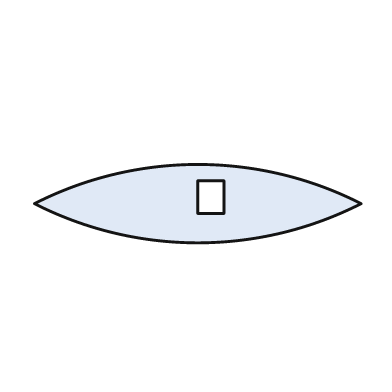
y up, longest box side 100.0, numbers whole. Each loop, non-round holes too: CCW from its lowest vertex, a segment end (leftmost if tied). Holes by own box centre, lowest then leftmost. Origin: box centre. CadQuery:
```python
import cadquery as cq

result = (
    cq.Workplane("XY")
    .moveTo(-50.0, 0.0)
    .threePointArc((0.0, -12.0), (50.0, 0.0))
    .threePointArc((0.0, 12.0), (-50.0, 0.0))
    .close()
    .moveTo(0.0, -3.0)
    .lineTo(8.0, -3.0)
    .lineTo(8.0, 7.0)
    .lineTo(0.0, 7.0)
    .close()
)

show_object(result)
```